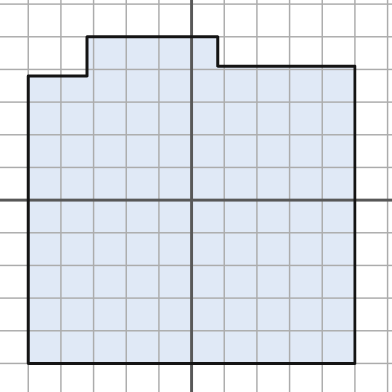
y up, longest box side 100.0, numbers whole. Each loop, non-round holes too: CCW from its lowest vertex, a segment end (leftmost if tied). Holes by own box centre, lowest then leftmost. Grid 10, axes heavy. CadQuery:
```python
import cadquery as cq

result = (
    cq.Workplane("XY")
    .moveTo(-50.0, -50.0)
    .lineTo(50.0, -50.0)
    .lineTo(50.0, 41.0)
    .lineTo(8.0, 41.0)
    .lineTo(8.0, 50.0)
    .lineTo(-32.0, 50.0)
    .lineTo(-32.0, 38.0)
    .lineTo(-50.0, 38.0)
    .close()
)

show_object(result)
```